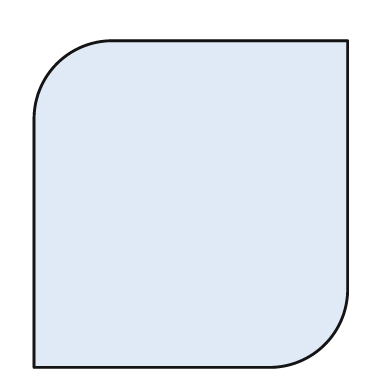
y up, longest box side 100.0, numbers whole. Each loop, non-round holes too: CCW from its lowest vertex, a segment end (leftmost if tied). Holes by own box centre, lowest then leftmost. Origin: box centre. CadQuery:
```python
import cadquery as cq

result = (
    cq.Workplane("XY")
    .moveTo(-48.0, -50.0)
    .lineTo(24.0, -50.0)
    .threePointArc((41.0, -43.0), (48.0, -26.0))
    .lineTo(48.0, 50.0)
    .lineTo(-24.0, 50.0)
    .threePointArc((-41.0, 43.0), (-48.0, 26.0))
    .close()
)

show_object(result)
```